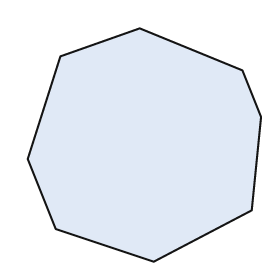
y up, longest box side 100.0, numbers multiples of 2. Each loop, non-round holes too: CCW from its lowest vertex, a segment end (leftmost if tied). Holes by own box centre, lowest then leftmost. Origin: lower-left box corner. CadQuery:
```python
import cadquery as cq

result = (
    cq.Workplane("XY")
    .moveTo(54.0, 0.0)
    .lineTo(96.0, 22.0)
    .lineTo(100.0, 62.0)
    .lineTo(92.0, 82.0)
    .lineTo(48.0, 100.0)
    .lineTo(14.0, 88.0)
    .lineTo(0.0, 44.0)
    .lineTo(12.0, 14.0)
    .close()
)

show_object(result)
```